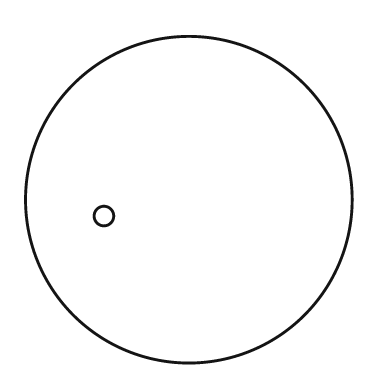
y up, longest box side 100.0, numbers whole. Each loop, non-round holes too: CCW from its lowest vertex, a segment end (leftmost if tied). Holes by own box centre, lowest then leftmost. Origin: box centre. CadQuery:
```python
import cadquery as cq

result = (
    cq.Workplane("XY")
    .moveTo(0.0, 0.0)
    .circle(50.0)
    .moveTo(-26.0, -5.0)
    .circle(3.0)
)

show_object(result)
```